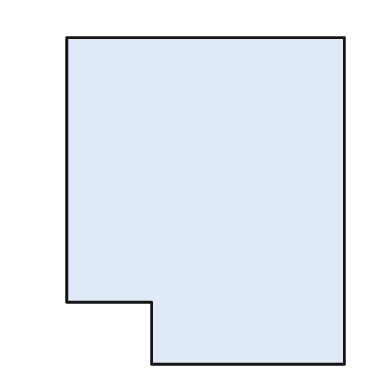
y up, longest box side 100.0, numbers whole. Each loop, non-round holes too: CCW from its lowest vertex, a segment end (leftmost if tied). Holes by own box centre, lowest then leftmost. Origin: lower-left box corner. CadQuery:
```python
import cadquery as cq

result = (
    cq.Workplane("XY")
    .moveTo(26.0, 0.0)
    .lineTo(85.0, 0.0)
    .lineTo(85.0, 100.0)
    .lineTo(0.0, 100.0)
    .lineTo(0.0, 19.0)
    .lineTo(26.0, 19.0)
    .close()
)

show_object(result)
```